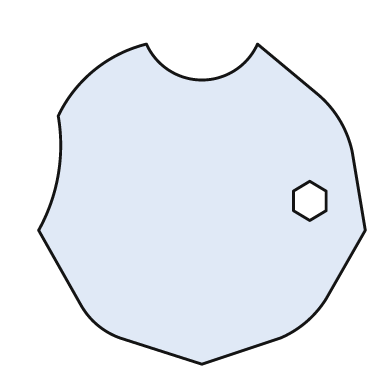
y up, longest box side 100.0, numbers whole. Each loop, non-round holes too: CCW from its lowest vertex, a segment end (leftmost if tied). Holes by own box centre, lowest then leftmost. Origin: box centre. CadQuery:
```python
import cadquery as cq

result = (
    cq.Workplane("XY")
    .moveTo(0.0, -49.0)
    .lineTo(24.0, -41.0)
    .threePointArc((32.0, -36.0), (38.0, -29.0))
    .lineTo(50.0, -8.0)
    .lineTo(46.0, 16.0)
    .threePointArc((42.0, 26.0), (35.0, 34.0))
    .lineTo(17.0, 49.0)
    .threePointArc((0.0, 38.0), (-17.0, 49.0))
    .threePointArc((-33.0, 41.0), (-44.0, 27.0))
    .threePointArc((-44.0, 9.0), (-50.0, -8.0))
    .lineTo(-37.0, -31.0)
    .threePointArc((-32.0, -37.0), (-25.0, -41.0))
    .close()
    .moveTo(33.0, -5.0)
    .lineTo(38.0, -2.0)
    .lineTo(38.0, 4.0)
    .lineTo(33.0, 7.0)
    .lineTo(28.0, 4.0)
    .lineTo(28.0, -2.0)
    .close()
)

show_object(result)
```